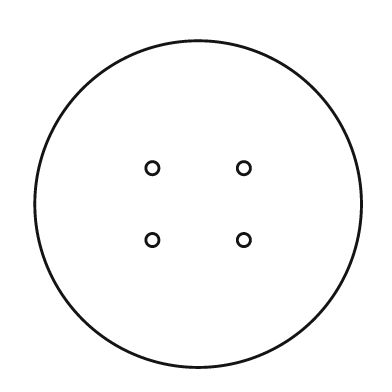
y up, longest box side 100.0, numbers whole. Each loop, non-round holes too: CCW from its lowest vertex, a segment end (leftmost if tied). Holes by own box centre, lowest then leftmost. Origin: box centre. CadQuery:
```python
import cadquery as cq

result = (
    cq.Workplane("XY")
    .moveTo(0.0, 0.0)
    .circle(50.0)
    .moveTo(-14.0, -11.0)
    .circle(2.0)
    .moveTo(14.0, -11.0)
    .circle(2.0)
    .moveTo(-14.0, 11.0)
    .circle(2.0)
    .moveTo(14.0, 11.0)
    .circle(2.0)
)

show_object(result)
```